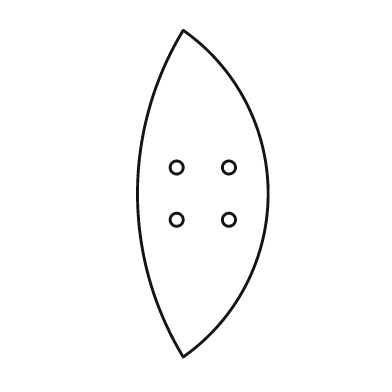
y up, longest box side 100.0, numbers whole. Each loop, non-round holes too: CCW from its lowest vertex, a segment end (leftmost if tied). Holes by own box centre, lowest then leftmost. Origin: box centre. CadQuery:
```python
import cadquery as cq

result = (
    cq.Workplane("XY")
    .moveTo(-6.0, -50.0)
    .threePointArc((20.0, 0.0), (-6.0, 50.0))
    .threePointArc((-20.0, 0.0), (-6.0, -50.0))
    .close()
    .moveTo(-8.0, -8.0)
    .circle(2.0)
    .moveTo(8.0, -8.0)
    .circle(2.0)
    .moveTo(-8.0, 8.0)
    .circle(2.0)
    .moveTo(8.0, 8.0)
    .circle(2.0)
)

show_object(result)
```